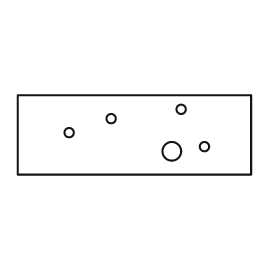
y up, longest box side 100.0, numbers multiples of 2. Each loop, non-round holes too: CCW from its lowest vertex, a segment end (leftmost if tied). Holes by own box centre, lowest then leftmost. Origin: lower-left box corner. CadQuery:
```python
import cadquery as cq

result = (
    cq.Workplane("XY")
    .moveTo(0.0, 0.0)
    .lineTo(100.0, 0.0)
    .lineTo(100.0, 34.0)
    .lineTo(0.0, 34.0)
    .close()
    .moveTo(66.0, 10.0)
    .circle(4.0)
    .moveTo(80.0, 12.0)
    .circle(2.0)
    .moveTo(22.0, 18.0)
    .circle(2.0)
    .moveTo(40.0, 24.0)
    .circle(2.0)
    .moveTo(70.0, 28.0)
    .circle(2.0)
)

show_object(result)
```